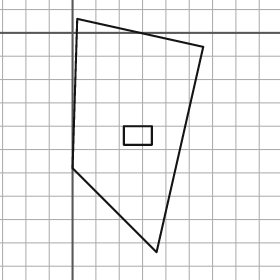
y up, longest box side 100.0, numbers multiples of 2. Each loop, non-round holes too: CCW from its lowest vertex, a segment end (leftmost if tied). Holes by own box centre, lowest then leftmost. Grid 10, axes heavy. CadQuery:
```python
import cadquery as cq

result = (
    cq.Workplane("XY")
    .moveTo(36.0, -94.0)
    .lineTo(56.0, -6.0)
    .lineTo(2.0, 6.0)
    .lineTo(0.0, -58.0)
    .close()
    .moveTo(22.0, -48.0)
    .lineTo(34.0, -48.0)
    .lineTo(34.0, -40.0)
    .lineTo(22.0, -40.0)
    .close()
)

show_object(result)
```